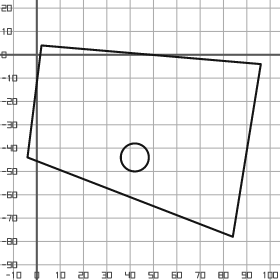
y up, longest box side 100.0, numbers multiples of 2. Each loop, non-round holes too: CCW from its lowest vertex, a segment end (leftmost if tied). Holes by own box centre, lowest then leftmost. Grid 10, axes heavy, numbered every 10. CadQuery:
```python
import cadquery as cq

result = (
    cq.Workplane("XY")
    .moveTo(84.0, -78.0)
    .lineTo(96.0, -4.0)
    .lineTo(2.0, 4.0)
    .lineTo(-4.0, -44.0)
    .close()
    .moveTo(42.0, -44.0)
    .circle(6.0)
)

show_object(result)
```